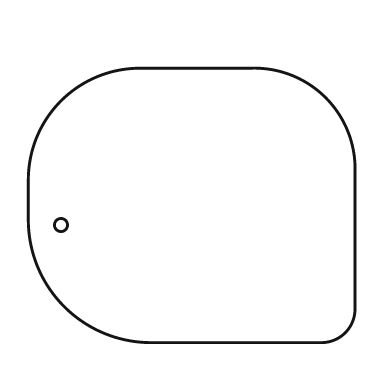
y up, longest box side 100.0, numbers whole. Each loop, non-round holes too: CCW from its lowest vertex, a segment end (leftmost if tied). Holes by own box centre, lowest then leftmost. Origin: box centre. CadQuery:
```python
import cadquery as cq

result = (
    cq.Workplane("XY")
    .moveTo(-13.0, -42.0)
    .lineTo(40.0, -42.0)
    .threePointArc((47.0, -39.0), (50.0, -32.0))
    .lineTo(50.0, 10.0)
    .threePointArc((41.0, 33.0), (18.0, 42.0))
    .lineTo(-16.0, 42.0)
    .threePointArc((-40.0, 32.0), (-50.0, 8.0))
    .lineTo(-50.0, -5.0)
    .threePointArc((-39.0, -31.0), (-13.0, -42.0))
    .close()
    .moveTo(-40.0, -6.0)
    .circle(2.0)
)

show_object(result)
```